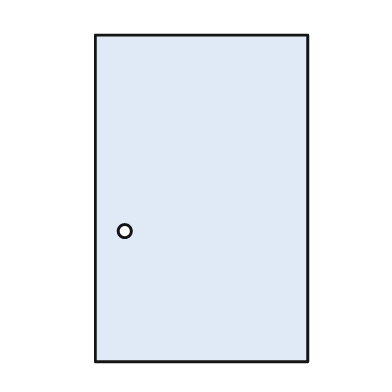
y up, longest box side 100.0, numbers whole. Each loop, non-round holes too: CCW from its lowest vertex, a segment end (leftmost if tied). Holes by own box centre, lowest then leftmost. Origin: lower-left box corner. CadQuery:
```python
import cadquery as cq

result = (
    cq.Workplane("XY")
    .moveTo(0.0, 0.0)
    .lineTo(65.0, 0.0)
    .lineTo(65.0, 100.0)
    .lineTo(0.0, 100.0)
    .close()
    .moveTo(9.0, 40.0)
    .circle(2.0)
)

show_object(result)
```